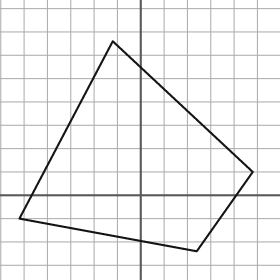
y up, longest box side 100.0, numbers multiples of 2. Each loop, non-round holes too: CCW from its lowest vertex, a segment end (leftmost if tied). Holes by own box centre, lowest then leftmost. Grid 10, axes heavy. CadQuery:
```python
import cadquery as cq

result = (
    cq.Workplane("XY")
    .moveTo(24.0, -24.0)
    .lineTo(48.0, 10.0)
    .lineTo(-12.0, 66.0)
    .lineTo(-52.0, -10.0)
    .close()
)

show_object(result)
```